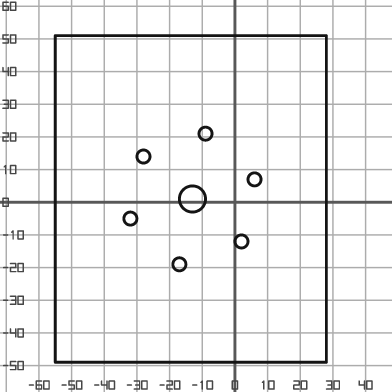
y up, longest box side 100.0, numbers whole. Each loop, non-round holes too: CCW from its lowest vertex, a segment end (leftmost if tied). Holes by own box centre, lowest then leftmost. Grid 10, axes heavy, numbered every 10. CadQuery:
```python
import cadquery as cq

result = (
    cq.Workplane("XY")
    .moveTo(-55.0, -49.0)
    .lineTo(28.0, -49.0)
    .lineTo(28.0, 51.0)
    .lineTo(-55.0, 51.0)
    .close()
    .moveTo(-17.0, -19.0)
    .circle(2.0)
    .moveTo(2.0, -12.0)
    .circle(2.0)
    .moveTo(-32.0, -5.0)
    .circle(2.0)
    .moveTo(-13.0, 1.0)
    .circle(4.0)
    .moveTo(6.0, 7.0)
    .circle(2.0)
    .moveTo(-28.0, 14.0)
    .circle(2.0)
    .moveTo(-9.0, 21.0)
    .circle(2.0)
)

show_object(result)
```